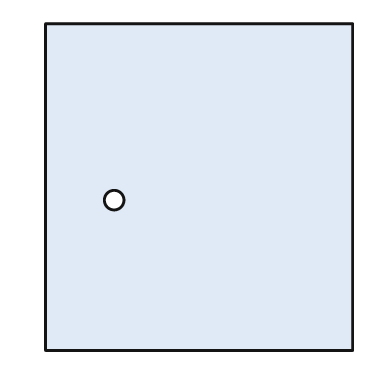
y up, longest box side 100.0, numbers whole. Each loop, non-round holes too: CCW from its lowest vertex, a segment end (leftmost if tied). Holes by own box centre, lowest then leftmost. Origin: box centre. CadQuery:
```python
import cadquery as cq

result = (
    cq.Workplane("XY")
    .moveTo(-47.0, -50.0)
    .lineTo(47.0, -50.0)
    .lineTo(47.0, 50.0)
    .lineTo(-47.0, 50.0)
    .close()
    .moveTo(-26.0, -4.0)
    .circle(3.0)
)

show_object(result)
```